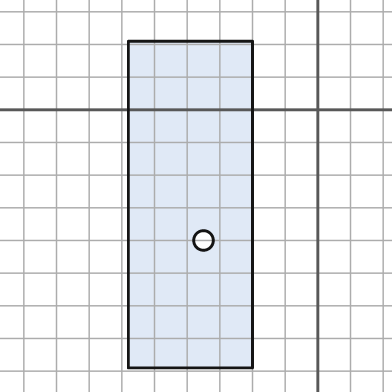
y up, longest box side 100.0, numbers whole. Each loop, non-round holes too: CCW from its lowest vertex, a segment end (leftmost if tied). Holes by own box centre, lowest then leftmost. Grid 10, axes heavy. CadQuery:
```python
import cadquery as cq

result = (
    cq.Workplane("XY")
    .moveTo(-58.0, -79.0)
    .lineTo(-20.0, -79.0)
    .lineTo(-20.0, 21.0)
    .lineTo(-58.0, 21.0)
    .close()
    .moveTo(-35.0, -40.0)
    .circle(3.0)
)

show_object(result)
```